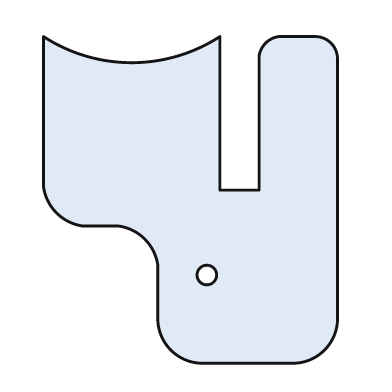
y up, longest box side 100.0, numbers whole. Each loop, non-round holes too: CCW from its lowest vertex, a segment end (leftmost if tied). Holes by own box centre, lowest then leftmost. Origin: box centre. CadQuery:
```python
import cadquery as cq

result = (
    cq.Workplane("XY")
    .moveTo(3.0, -50.0)
    .lineTo(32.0, -50.0)
    .threePointArc((41.0, -46.0), (45.0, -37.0))
    .lineTo(45.0, 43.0)
    .threePointArc((43.0, 48.0), (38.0, 50.0))
    .lineTo(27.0, 50.0)
    .threePointArc((23.0, 48.0), (21.0, 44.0))
    .lineTo(21.0, 3.0)
    .lineTo(9.0, 3.0)
    .lineTo(9.0, 50.0)
    .threePointArc((-18.0, 42.0), (-45.0, 50.0))
    .lineTo(-45.0, 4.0)
    .threePointArc((-41.0, -4.0), (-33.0, -8.0))
    .lineTo(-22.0, -8.0)
    .threePointArc((-14.0, -12.0), (-10.0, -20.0))
    .lineTo(-10.0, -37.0)
    .threePointArc((-6.0, -46.0), (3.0, -50.0))
    .close()
    .moveTo(5.0, -23.0)
    .circle(3.0)
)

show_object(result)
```